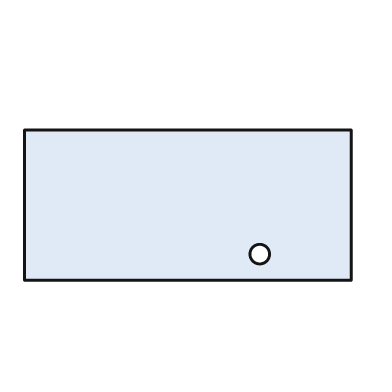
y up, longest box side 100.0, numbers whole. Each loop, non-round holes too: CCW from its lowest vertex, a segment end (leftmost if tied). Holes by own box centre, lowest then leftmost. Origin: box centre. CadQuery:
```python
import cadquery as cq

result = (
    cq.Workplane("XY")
    .moveTo(-50.0, -23.0)
    .lineTo(50.0, -23.0)
    .lineTo(50.0, 23.0)
    .lineTo(-50.0, 23.0)
    .close()
    .moveTo(22.0, -15.0)
    .circle(3.0)
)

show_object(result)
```